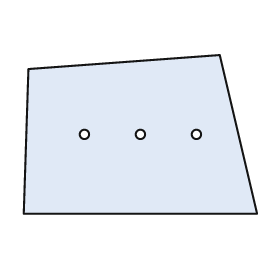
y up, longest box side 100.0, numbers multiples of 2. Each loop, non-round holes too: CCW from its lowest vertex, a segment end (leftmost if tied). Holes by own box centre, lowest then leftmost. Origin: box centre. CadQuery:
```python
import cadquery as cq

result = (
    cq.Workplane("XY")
    .moveTo(-50.0, -34.0)
    .lineTo(50.0, -34.0)
    .lineTo(34.0, 34.0)
    .lineTo(-48.0, 28.0)
    .close()
    .moveTo(-24.0, 0.0)
    .circle(2.0)
    .moveTo(0.0, 0.0)
    .circle(2.0)
    .moveTo(24.0, 0.0)
    .circle(2.0)
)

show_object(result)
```